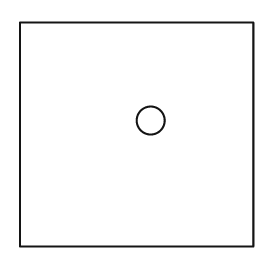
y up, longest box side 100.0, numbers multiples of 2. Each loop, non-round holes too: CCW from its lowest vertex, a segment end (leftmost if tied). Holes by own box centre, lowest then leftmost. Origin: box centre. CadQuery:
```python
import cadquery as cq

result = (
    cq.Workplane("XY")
    .moveTo(-50.0, -48.0)
    .lineTo(50.0, -48.0)
    .lineTo(50.0, 48.0)
    .lineTo(-50.0, 48.0)
    .close()
    .moveTo(6.0, 6.0)
    .circle(6.0)
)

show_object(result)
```